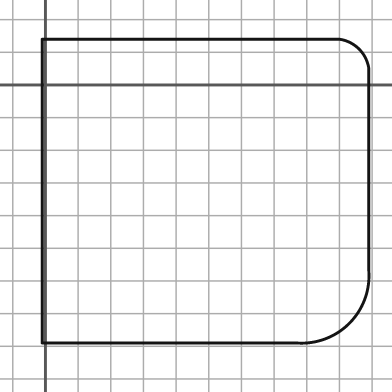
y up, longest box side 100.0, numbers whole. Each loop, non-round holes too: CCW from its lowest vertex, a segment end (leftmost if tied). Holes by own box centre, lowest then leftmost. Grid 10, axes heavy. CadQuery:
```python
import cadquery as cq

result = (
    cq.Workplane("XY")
    .moveTo(-1.0, -79.0)
    .lineTo(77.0, -79.0)
    .threePointArc((93.0, -73.0), (99.0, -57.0))
    .lineTo(99.0, 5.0)
    .threePointArc((96.0, 11.0), (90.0, 14.0))
    .lineTo(-1.0, 14.0)
    .close()
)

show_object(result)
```